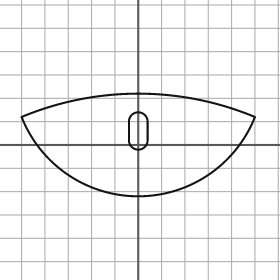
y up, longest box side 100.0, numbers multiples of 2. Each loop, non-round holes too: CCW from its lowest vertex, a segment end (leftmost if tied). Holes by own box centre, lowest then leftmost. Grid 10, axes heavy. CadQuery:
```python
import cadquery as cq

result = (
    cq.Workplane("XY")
    .moveTo(-50.0, 12.0)
    .threePointArc((0.0, -22.0), (50.0, 12.0))
    .threePointArc((0.0, 22.0), (-50.0, 12.0))
    .close()
    .moveTo(-4.0, 2.0)
    .threePointArc((0.0, -2.0), (4.0, 2.0))
    .lineTo(4.0, 10.0)
    .threePointArc((0.0, 14.0), (-4.0, 10.0))
    .close()
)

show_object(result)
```